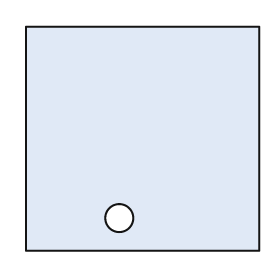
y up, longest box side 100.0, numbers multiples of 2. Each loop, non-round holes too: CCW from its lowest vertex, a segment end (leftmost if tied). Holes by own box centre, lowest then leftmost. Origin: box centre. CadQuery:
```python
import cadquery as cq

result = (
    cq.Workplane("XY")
    .moveTo(-50.0, -48.0)
    .lineTo(50.0, -48.0)
    .lineTo(50.0, 48.0)
    .lineTo(-50.0, 48.0)
    .close()
    .moveTo(-10.0, -34.0)
    .circle(6.0)
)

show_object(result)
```